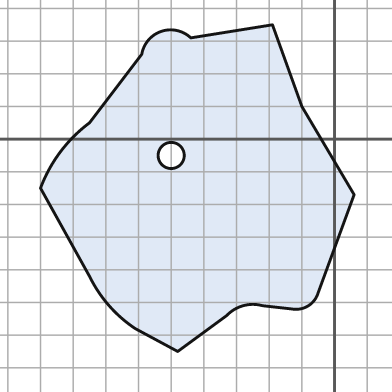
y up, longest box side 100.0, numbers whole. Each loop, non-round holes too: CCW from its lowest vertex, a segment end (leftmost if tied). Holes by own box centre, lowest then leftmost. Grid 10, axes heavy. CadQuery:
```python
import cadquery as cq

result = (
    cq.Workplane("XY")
    .moveTo(-48.0, -65.0)
    .lineTo(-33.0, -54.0)
    .threePointArc((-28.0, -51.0), (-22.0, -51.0))
    .lineTo(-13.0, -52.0)
    .threePointArc((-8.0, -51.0), (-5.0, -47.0))
    .lineTo(6.0, -17.0)
    .lineTo(-10.0, 10.0)
    .lineTo(-19.0, 35.0)
    .lineTo(-44.0, 31.0)
    .threePointArc((-53.0, 33.0), (-59.0, 26.0))
    .lineTo(-75.0, 5.0)
    .threePointArc((-84.0, -4.0), (-90.0, -15.0))
    .lineTo(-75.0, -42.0)
    .threePointArc((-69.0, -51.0), (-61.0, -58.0))
    .close()
    .moveTo(-50.0, -5.0)
    .circle(4.0)
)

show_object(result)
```